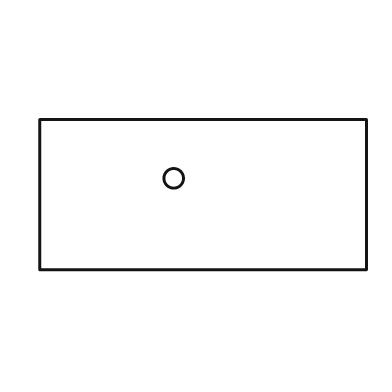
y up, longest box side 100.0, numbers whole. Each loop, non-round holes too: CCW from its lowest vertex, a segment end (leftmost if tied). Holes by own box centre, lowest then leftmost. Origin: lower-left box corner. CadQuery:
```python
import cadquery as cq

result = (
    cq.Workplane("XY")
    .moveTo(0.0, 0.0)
    .lineTo(100.0, 0.0)
    .lineTo(100.0, 46.0)
    .lineTo(0.0, 46.0)
    .close()
    .moveTo(41.0, 28.0)
    .circle(3.0)
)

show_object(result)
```